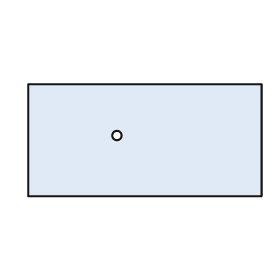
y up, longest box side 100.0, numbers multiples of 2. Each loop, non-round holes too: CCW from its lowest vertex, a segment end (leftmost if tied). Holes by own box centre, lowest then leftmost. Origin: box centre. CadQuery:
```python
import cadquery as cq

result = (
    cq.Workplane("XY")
    .moveTo(-50.0, -24.0)
    .lineTo(50.0, -24.0)
    .lineTo(50.0, 24.0)
    .lineTo(-50.0, 24.0)
    .close()
    .moveTo(-12.0, 2.0)
    .circle(2.0)
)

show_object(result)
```